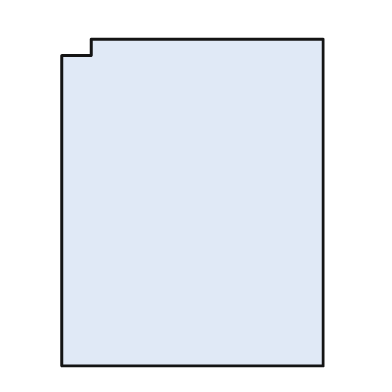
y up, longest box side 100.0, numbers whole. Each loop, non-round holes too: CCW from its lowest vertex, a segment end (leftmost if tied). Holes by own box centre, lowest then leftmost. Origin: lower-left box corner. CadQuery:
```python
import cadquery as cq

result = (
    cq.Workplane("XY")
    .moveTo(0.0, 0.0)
    .lineTo(80.0, 0.0)
    .lineTo(80.0, 100.0)
    .lineTo(9.0, 100.0)
    .lineTo(9.0, 95.0)
    .lineTo(0.0, 95.0)
    .close()
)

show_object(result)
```